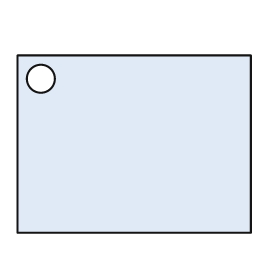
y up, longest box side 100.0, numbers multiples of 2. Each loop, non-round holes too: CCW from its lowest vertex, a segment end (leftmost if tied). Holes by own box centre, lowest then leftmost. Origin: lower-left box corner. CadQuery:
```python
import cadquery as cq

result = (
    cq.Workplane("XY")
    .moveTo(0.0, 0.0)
    .lineTo(100.0, 0.0)
    .lineTo(100.0, 76.0)
    .lineTo(0.0, 76.0)
    .close()
    .moveTo(10.0, 66.0)
    .circle(6.0)
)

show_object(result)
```